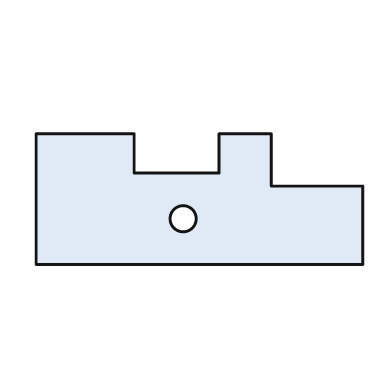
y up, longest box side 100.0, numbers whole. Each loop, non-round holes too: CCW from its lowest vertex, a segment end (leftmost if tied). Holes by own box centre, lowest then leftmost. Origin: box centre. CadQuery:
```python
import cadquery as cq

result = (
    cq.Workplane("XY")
    .moveTo(-50.0, -20.0)
    .lineTo(50.0, -20.0)
    .lineTo(50.0, 4.0)
    .lineTo(22.0, 4.0)
    .lineTo(22.0, 20.0)
    .lineTo(6.0, 20.0)
    .lineTo(6.0, 8.0)
    .lineTo(-20.0, 8.0)
    .lineTo(-20.0, 20.0)
    .lineTo(-50.0, 20.0)
    .close()
    .moveTo(-5.0, -6.0)
    .circle(4.0)
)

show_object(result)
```